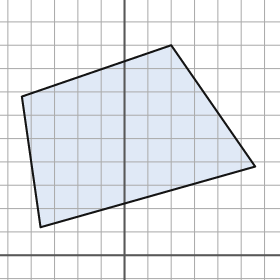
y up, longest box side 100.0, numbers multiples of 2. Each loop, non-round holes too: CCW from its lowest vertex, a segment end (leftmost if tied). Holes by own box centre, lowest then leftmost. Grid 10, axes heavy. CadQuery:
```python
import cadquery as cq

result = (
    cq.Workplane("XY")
    .moveTo(-36.0, 12.0)
    .lineTo(56.0, 38.0)
    .lineTo(20.0, 90.0)
    .lineTo(-44.0, 68.0)
    .close()
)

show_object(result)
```